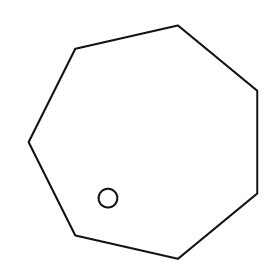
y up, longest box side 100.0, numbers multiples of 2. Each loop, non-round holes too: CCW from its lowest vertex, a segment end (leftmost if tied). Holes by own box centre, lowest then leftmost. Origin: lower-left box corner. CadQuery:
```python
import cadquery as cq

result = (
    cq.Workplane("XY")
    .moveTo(64.0, 0.0)
    .lineTo(98.0, 28.0)
    .lineTo(98.0, 72.0)
    .lineTo(64.0, 100.0)
    .lineTo(20.0, 90.0)
    .lineTo(0.0, 50.0)
    .lineTo(20.0, 10.0)
    .close()
    .moveTo(34.0, 26.0)
    .circle(4.0)
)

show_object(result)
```